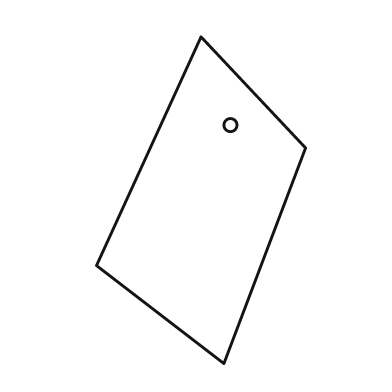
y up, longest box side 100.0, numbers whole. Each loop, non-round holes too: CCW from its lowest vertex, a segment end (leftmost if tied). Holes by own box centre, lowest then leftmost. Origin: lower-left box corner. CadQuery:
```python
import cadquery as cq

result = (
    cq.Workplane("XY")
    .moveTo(39.0, 0.0)
    .lineTo(64.0, 66.0)
    .lineTo(32.0, 100.0)
    .lineTo(0.0, 30.0)
    .close()
    .moveTo(41.0, 73.0)
    .circle(2.0)
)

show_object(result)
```